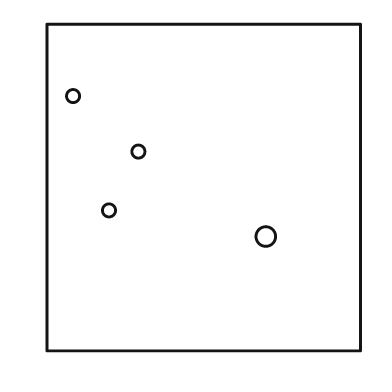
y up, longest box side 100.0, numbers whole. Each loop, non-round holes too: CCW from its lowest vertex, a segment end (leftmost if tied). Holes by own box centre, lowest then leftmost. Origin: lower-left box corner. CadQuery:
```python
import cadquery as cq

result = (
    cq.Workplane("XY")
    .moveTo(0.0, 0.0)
    .lineTo(96.0, 0.0)
    .lineTo(96.0, 100.0)
    .lineTo(0.0, 100.0)
    .close()
    .moveTo(67.0, 35.0)
    .circle(3.0)
    .moveTo(19.0, 43.0)
    .circle(2.0)
    .moveTo(28.0, 61.0)
    .circle(2.0)
    .moveTo(8.0, 78.0)
    .circle(2.0)
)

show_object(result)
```